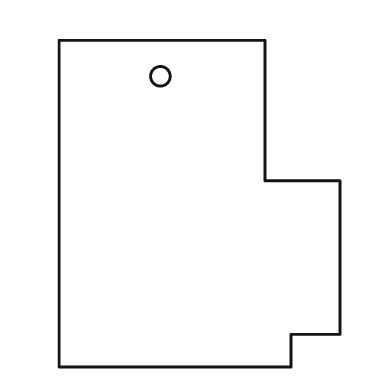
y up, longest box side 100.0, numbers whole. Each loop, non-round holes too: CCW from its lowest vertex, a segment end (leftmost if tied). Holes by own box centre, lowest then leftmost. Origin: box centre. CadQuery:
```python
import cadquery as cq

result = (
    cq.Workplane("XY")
    .moveTo(-43.0, -50.0)
    .lineTo(28.0, -50.0)
    .lineTo(28.0, -40.0)
    .lineTo(43.0, -40.0)
    .lineTo(43.0, 7.0)
    .lineTo(20.0, 7.0)
    .lineTo(20.0, 50.0)
    .lineTo(-43.0, 50.0)
    .close()
    .moveTo(-12.0, 39.0)
    .circle(3.0)
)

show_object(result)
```